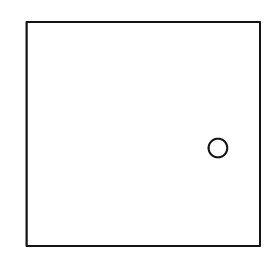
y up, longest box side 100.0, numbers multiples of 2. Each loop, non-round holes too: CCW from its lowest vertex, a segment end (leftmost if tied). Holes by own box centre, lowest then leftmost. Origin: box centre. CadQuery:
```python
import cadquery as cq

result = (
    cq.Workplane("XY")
    .moveTo(-50.0, -48.0)
    .lineTo(50.0, -48.0)
    .lineTo(50.0, 48.0)
    .lineTo(-50.0, 48.0)
    .close()
    .moveTo(32.0, -6.0)
    .circle(4.0)
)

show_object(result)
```